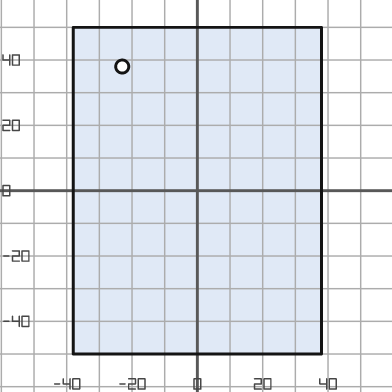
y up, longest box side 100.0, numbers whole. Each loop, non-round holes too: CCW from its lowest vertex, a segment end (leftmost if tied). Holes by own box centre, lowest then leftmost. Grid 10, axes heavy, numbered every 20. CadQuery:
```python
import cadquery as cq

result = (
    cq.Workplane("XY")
    .moveTo(-38.0, -50.0)
    .lineTo(38.0, -50.0)
    .lineTo(38.0, 50.0)
    .lineTo(-38.0, 50.0)
    .close()
    .moveTo(-23.0, 38.0)
    .circle(2.0)
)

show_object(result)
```